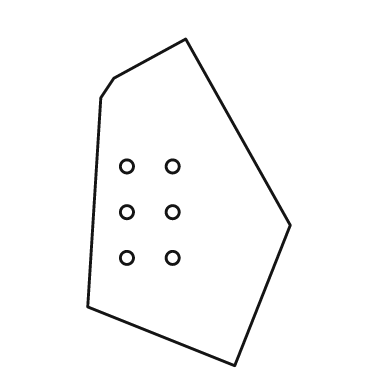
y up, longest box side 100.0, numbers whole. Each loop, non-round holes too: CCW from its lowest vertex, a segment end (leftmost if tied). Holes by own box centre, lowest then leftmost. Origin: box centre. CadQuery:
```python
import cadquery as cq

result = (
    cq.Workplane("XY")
    .moveTo(14.0, -50.0)
    .lineTo(31.0, -7.0)
    .lineTo(-1.0, 50.0)
    .lineTo(-23.0, 38.0)
    .lineTo(-27.0, 32.0)
    .lineTo(-31.0, -32.0)
    .close()
    .moveTo(-19.0, -17.0)
    .circle(2.0)
    .moveTo(-5.0, -17.0)
    .circle(2.0)
    .moveTo(-19.0, -3.0)
    .circle(2.0)
    .moveTo(-5.0, -3.0)
    .circle(2.0)
    .moveTo(-19.0, 11.0)
    .circle(2.0)
    .moveTo(-5.0, 11.0)
    .circle(2.0)
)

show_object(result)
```